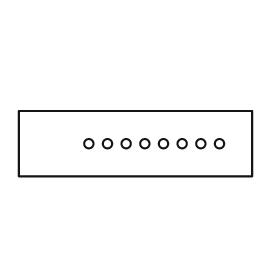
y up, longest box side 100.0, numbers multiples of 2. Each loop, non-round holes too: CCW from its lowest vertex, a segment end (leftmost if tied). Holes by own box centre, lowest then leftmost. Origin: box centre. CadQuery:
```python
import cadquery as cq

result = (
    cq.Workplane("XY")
    .moveTo(-50.0, -14.0)
    .lineTo(50.0, -14.0)
    .lineTo(50.0, 14.0)
    .lineTo(-50.0, 14.0)
    .close()
    .moveTo(-20.0, 0.0)
    .circle(2.0)
    .moveTo(-12.0, 0.0)
    .circle(2.0)
    .moveTo(-4.0, 0.0)
    .circle(2.0)
    .moveTo(4.0, 0.0)
    .circle(2.0)
    .moveTo(12.0, 0.0)
    .circle(2.0)
    .moveTo(20.0, 0.0)
    .circle(2.0)
    .moveTo(28.0, 0.0)
    .circle(2.0)
    .moveTo(36.0, 0.0)
    .circle(2.0)
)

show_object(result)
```